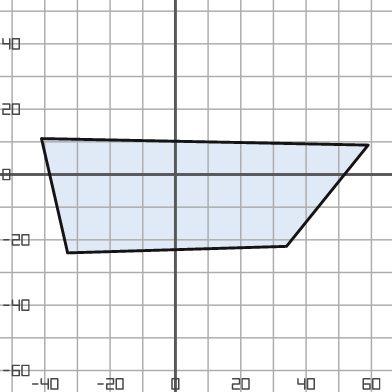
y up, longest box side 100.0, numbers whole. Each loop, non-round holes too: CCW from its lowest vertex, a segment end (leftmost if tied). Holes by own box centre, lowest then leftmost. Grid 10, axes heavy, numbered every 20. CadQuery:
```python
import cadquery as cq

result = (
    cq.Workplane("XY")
    .moveTo(-33.0, -24.0)
    .lineTo(34.0, -22.0)
    .lineTo(59.0, 9.0)
    .lineTo(-41.0, 11.0)
    .close()
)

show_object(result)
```